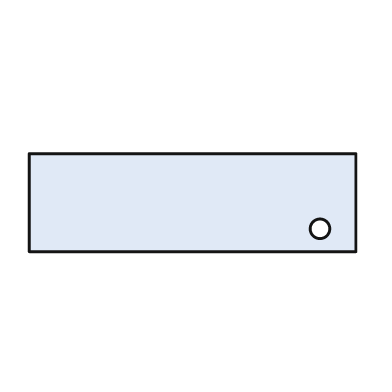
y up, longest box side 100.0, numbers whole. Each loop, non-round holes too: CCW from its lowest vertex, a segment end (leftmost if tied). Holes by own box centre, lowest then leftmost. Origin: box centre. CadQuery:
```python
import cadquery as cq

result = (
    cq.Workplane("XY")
    .moveTo(-50.0, -15.0)
    .lineTo(50.0, -15.0)
    .lineTo(50.0, 15.0)
    .lineTo(-50.0, 15.0)
    .close()
    .moveTo(39.0, -8.0)
    .circle(3.0)
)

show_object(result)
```